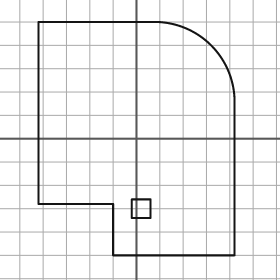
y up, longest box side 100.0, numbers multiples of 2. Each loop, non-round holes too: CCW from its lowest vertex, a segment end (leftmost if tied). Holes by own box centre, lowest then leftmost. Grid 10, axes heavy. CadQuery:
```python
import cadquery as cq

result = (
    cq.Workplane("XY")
    .moveTo(-10.0, -50.0)
    .lineTo(42.0, -50.0)
    .lineTo(42.0, 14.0)
    .threePointArc((32.0, 40.0), (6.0, 50.0))
    .lineTo(-42.0, 50.0)
    .lineTo(-42.0, -28.0)
    .lineTo(-10.0, -28.0)
    .close()
    .moveTo(-2.0, -34.0)
    .lineTo(6.0, -34.0)
    .lineTo(6.0, -26.0)
    .lineTo(-2.0, -26.0)
    .close()
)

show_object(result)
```